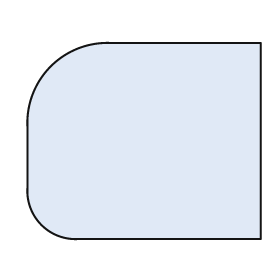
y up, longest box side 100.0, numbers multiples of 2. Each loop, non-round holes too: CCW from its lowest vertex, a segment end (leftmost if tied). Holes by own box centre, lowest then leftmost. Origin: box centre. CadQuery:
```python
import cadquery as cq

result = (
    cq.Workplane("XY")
    .moveTo(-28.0, -42.0)
    .lineTo(50.0, -42.0)
    .lineTo(50.0, 42.0)
    .lineTo(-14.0, 42.0)
    .threePointArc((-40.0, 32.0), (-50.0, 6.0))
    .lineTo(-50.0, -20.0)
    .threePointArc((-44.0, -36.0), (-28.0, -42.0))
    .close()
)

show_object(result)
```